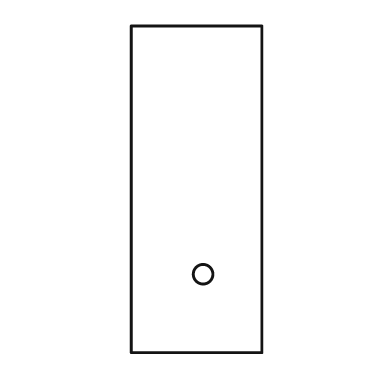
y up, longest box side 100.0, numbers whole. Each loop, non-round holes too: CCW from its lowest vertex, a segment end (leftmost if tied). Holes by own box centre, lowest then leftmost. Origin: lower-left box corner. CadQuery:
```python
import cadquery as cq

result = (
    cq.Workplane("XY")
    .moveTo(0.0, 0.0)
    .lineTo(40.0, 0.0)
    .lineTo(40.0, 100.0)
    .lineTo(0.0, 100.0)
    .close()
    .moveTo(22.0, 24.0)
    .circle(3.0)
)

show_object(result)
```